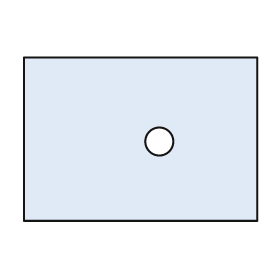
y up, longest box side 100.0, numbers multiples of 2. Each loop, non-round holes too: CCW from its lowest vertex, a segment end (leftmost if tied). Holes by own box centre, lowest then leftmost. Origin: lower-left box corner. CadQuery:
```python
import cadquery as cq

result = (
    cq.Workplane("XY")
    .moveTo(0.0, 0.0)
    .lineTo(100.0, 0.0)
    .lineTo(100.0, 70.0)
    .lineTo(0.0, 70.0)
    .close()
    .moveTo(58.0, 34.0)
    .circle(6.0)
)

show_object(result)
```